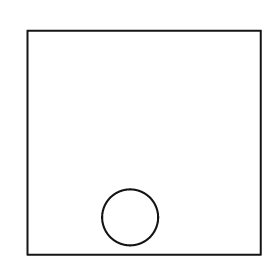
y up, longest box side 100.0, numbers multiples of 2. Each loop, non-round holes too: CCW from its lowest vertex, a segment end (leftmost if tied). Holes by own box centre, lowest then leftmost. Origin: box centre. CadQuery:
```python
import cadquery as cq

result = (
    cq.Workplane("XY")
    .moveTo(-50.0, -48.0)
    .lineTo(50.0, -48.0)
    .lineTo(50.0, 48.0)
    .lineTo(-50.0, 48.0)
    .close()
    .moveTo(-6.0, -32.0)
    .circle(12.0)
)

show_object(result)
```